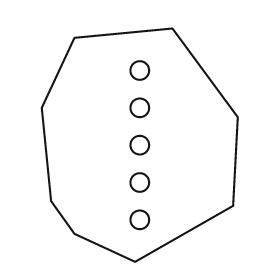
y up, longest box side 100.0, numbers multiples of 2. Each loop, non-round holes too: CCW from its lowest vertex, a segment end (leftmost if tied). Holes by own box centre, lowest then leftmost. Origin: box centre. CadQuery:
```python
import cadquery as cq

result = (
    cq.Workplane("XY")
    .moveTo(-2.0, -50.0)
    .lineTo(40.0, -26.0)
    .lineTo(42.0, 12.0)
    .lineTo(14.0, 50.0)
    .lineTo(-28.0, 46.0)
    .lineTo(-42.0, 16.0)
    .lineTo(-38.0, -24.0)
    .lineTo(-28.0, -38.0)
    .close()
    .moveTo(0.0, -32.0)
    .circle(4.0)
    .moveTo(0.0, -16.0)
    .circle(4.0)
    .moveTo(0.0, 0.0)
    .circle(4.0)
    .moveTo(0.0, 16.0)
    .circle(4.0)
    .moveTo(0.0, 32.0)
    .circle(4.0)
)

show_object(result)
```